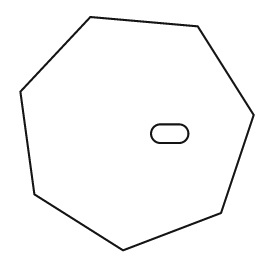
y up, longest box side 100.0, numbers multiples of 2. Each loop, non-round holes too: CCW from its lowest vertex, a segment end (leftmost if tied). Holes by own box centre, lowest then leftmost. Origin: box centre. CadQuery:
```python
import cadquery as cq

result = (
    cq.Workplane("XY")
    .moveTo(-6.0, -50.0)
    .lineTo(36.0, -34.0)
    .lineTo(50.0, 8.0)
    .lineTo(26.0, 46.0)
    .lineTo(-20.0, 50.0)
    .lineTo(-50.0, 18.0)
    .lineTo(-44.0, -26.0)
    .close()
    .moveTo(10.0, -4.0)
    .lineTo(18.0, -4.0)
    .threePointArc((22.0, 0.0), (18.0, 4.0))
    .lineTo(10.0, 4.0)
    .threePointArc((6.0, 0.0), (10.0, -4.0))
    .close()
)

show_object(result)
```